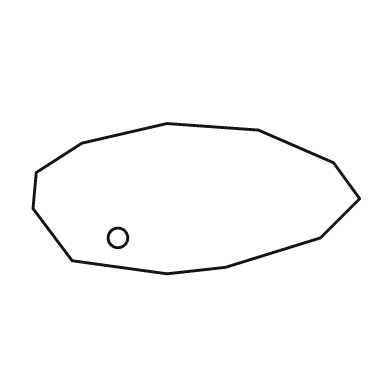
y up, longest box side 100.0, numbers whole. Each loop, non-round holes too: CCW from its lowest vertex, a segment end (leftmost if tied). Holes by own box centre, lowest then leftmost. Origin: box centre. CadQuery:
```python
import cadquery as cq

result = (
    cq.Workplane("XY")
    .moveTo(-9.0, -23.0)
    .lineTo(9.0, -21.0)
    .lineTo(38.0, -12.0)
    .lineTo(50.0, 0.0)
    .lineTo(42.0, 11.0)
    .lineTo(19.0, 21.0)
    .lineTo(-9.0, 23.0)
    .lineTo(-35.0, 17.0)
    .lineTo(-49.0, 8.0)
    .lineTo(-50.0, -3.0)
    .lineTo(-38.0, -19.0)
    .close()
    .moveTo(-24.0, -12.0)
    .circle(3.0)
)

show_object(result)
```